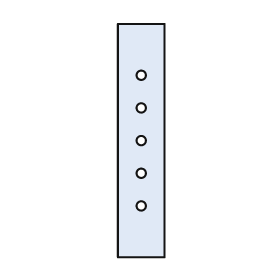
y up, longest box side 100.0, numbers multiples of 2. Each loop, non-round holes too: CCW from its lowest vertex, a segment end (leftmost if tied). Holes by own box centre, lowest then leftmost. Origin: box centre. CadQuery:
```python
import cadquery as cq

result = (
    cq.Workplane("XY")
    .moveTo(-10.0, -50.0)
    .lineTo(10.0, -50.0)
    .lineTo(10.0, 50.0)
    .lineTo(-10.0, 50.0)
    .close()
    .moveTo(0.0, -28.0)
    .circle(2.0)
    .moveTo(0.0, -14.0)
    .circle(2.0)
    .moveTo(0.0, 0.0)
    .circle(2.0)
    .moveTo(0.0, 14.0)
    .circle(2.0)
    .moveTo(0.0, 28.0)
    .circle(2.0)
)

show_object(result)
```